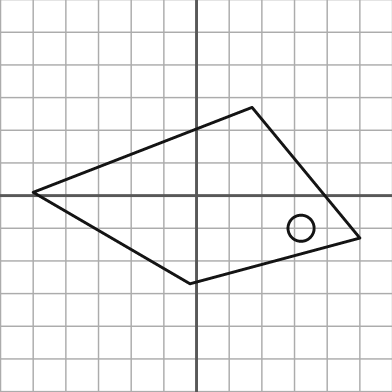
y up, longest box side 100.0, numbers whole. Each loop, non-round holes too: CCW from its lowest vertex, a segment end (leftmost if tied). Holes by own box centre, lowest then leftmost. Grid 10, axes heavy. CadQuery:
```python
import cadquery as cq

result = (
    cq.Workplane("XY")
    .moveTo(-2.0, -27.0)
    .lineTo(50.0, -13.0)
    .lineTo(17.0, 27.0)
    .lineTo(-50.0, 1.0)
    .close()
    .moveTo(32.0, -10.0)
    .circle(4.0)
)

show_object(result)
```